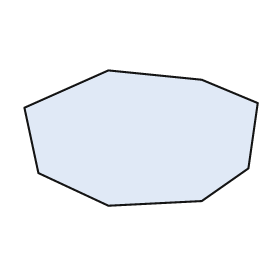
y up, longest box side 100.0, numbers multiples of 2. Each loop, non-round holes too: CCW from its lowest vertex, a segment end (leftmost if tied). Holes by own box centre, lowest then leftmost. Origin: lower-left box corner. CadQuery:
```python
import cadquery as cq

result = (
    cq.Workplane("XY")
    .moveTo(36.0, 0.0)
    .lineTo(76.0, 2.0)
    .lineTo(96.0, 16.0)
    .lineTo(100.0, 44.0)
    .lineTo(76.0, 54.0)
    .lineTo(36.0, 58.0)
    .lineTo(0.0, 42.0)
    .lineTo(6.0, 14.0)
    .close()
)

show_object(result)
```